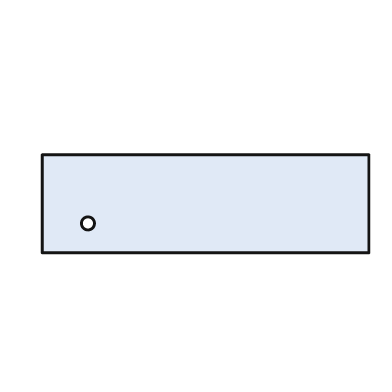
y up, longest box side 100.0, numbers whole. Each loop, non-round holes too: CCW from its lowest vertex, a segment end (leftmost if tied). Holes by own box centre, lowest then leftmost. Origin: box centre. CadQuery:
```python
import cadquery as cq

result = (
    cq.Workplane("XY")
    .moveTo(-50.0, -15.0)
    .lineTo(50.0, -15.0)
    .lineTo(50.0, 15.0)
    .lineTo(-50.0, 15.0)
    .close()
    .moveTo(-36.0, -6.0)
    .circle(2.0)
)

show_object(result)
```